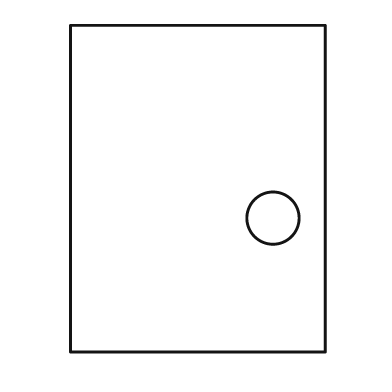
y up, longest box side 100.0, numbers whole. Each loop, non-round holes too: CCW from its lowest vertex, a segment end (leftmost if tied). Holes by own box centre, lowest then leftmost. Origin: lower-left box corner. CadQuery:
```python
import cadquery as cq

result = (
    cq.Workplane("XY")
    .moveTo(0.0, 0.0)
    .lineTo(78.0, 0.0)
    .lineTo(78.0, 100.0)
    .lineTo(0.0, 100.0)
    .close()
    .moveTo(62.0, 41.0)
    .circle(8.0)
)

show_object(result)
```